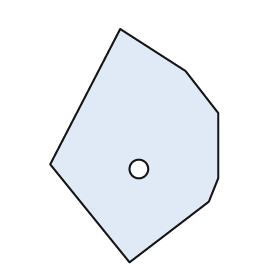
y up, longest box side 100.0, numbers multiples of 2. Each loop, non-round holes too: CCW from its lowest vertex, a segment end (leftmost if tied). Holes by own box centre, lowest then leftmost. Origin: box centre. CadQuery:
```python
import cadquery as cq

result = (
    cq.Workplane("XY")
    .moveTo(-2.0, -50.0)
    .lineTo(32.0, -24.0)
    .lineTo(36.0, -14.0)
    .lineTo(36.0, 14.0)
    .lineTo(22.0, 32.0)
    .lineTo(-6.0, 50.0)
    .lineTo(-36.0, -8.0)
    .close()
    .moveTo(2.0, -10.0)
    .circle(4.0)
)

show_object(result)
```